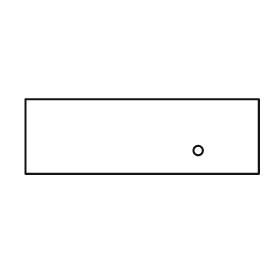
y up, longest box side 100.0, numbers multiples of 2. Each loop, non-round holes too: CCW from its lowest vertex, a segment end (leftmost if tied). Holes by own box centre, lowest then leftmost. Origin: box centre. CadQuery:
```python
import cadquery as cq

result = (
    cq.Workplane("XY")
    .moveTo(-50.0, -16.0)
    .lineTo(50.0, -16.0)
    .lineTo(50.0, 16.0)
    .lineTo(-50.0, 16.0)
    .close()
    .moveTo(24.0, -6.0)
    .circle(2.0)
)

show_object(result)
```